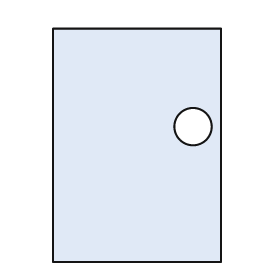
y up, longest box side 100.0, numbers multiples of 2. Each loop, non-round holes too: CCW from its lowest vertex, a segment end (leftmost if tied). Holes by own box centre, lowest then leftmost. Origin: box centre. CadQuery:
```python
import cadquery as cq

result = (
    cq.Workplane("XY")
    .moveTo(-36.0, -50.0)
    .lineTo(36.0, -50.0)
    .lineTo(36.0, 50.0)
    .lineTo(-36.0, 50.0)
    .close()
    .moveTo(24.0, 8.0)
    .circle(8.0)
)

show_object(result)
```